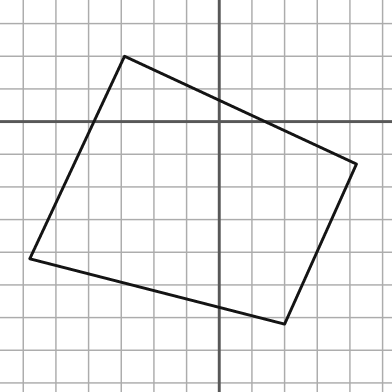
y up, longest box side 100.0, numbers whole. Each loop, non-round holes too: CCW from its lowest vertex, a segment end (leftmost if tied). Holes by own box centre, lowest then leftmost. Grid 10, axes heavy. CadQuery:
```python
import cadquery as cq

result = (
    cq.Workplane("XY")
    .moveTo(20.0, -62.0)
    .lineTo(42.0, -13.0)
    .lineTo(-29.0, 20.0)
    .lineTo(-58.0, -42.0)
    .close()
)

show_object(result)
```